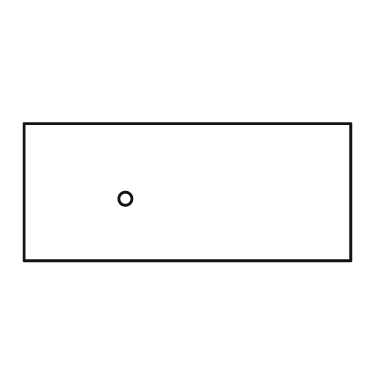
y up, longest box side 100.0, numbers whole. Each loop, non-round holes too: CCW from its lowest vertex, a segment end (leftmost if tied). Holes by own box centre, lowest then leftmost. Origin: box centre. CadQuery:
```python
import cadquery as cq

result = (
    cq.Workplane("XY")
    .moveTo(-50.0, -21.0)
    .lineTo(50.0, -21.0)
    .lineTo(50.0, 21.0)
    .lineTo(-50.0, 21.0)
    .close()
    .moveTo(-19.0, -2.0)
    .circle(2.0)
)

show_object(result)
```